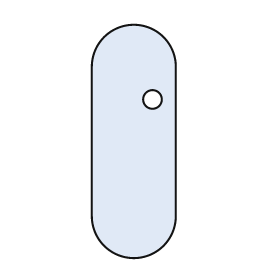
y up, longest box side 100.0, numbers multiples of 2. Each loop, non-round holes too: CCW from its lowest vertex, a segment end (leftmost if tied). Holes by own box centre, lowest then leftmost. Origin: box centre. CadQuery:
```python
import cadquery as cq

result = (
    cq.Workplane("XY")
    .moveTo(-18.0, -32.0)
    .threePointArc((0.0, -50.0), (18.0, -32.0))
    .lineTo(18.0, 32.0)
    .threePointArc((0.0, 50.0), (-18.0, 32.0))
    .close()
    .moveTo(8.0, 18.0)
    .circle(4.0)
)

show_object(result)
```